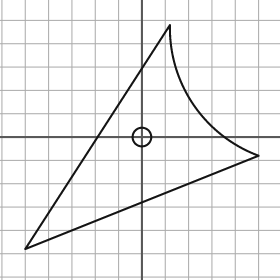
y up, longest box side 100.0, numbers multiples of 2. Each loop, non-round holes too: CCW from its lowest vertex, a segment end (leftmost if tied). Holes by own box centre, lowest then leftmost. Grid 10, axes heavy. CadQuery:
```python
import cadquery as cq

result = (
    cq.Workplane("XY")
    .moveTo(-50.0, -48.0)
    .lineTo(50.0, -8.0)
    .threePointArc((22.0, 14.0), (12.0, 48.0))
    .close()
    .moveTo(0.0, 0.0)
    .circle(4.0)
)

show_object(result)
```